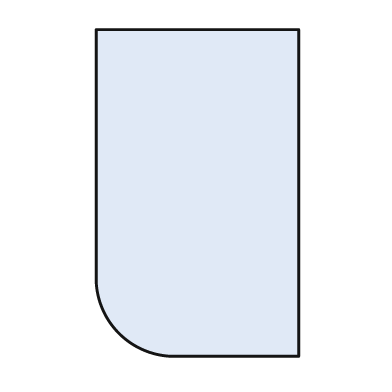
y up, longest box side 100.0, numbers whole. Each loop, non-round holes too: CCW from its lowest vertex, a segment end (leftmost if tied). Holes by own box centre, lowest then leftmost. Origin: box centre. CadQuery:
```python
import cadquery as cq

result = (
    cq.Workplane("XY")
    .moveTo(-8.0, -50.0)
    .lineTo(31.0, -50.0)
    .lineTo(31.0, 50.0)
    .lineTo(-31.0, 50.0)
    .lineTo(-31.0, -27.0)
    .threePointArc((-24.0, -43.0), (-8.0, -50.0))
    .close()
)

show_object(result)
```